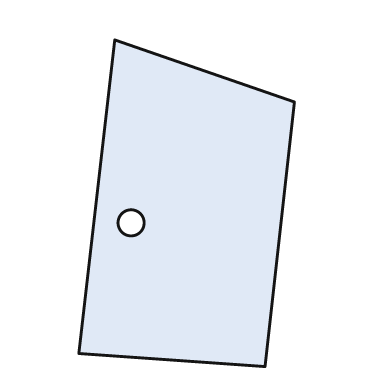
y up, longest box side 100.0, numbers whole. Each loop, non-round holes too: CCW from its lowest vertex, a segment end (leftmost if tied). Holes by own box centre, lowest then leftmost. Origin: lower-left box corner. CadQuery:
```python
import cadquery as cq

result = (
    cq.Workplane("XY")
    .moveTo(57.0, 0.0)
    .lineTo(66.0, 81.0)
    .lineTo(11.0, 100.0)
    .lineTo(0.0, 4.0)
    .close()
    .moveTo(16.0, 44.0)
    .circle(4.0)
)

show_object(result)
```